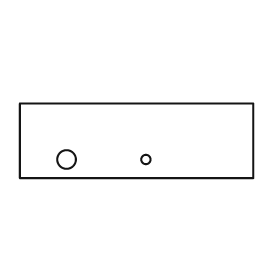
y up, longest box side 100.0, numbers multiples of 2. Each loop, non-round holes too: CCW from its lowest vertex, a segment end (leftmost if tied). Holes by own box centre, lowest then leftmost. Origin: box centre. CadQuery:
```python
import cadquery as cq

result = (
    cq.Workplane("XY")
    .moveTo(-50.0, -16.0)
    .lineTo(50.0, -16.0)
    .lineTo(50.0, 16.0)
    .lineTo(-50.0, 16.0)
    .close()
    .moveTo(-30.0, -8.0)
    .circle(4.0)
    .moveTo(4.0, -8.0)
    .circle(2.0)
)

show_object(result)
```